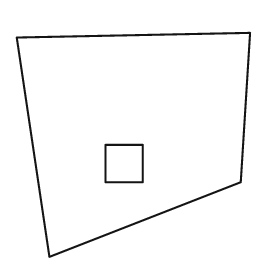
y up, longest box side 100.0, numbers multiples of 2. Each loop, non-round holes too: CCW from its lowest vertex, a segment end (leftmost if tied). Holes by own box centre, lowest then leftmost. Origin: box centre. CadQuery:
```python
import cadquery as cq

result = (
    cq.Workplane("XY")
    .moveTo(-36.0, -48.0)
    .lineTo(46.0, -16.0)
    .lineTo(50.0, 48.0)
    .lineTo(-50.0, 46.0)
    .close()
    .moveTo(-12.0, -16.0)
    .lineTo(4.0, -16.0)
    .lineTo(4.0, 0.0)
    .lineTo(-12.0, 0.0)
    .close()
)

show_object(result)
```